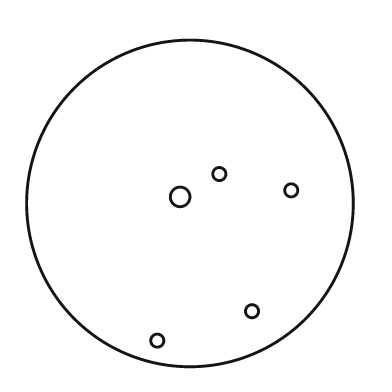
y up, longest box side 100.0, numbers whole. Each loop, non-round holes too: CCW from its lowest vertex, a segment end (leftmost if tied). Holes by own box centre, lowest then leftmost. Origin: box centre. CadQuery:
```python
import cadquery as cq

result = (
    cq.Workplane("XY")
    .moveTo(0.0, 0.0)
    .circle(50.0)
    .moveTo(-10.0, -42.0)
    .circle(2.0)
    .moveTo(19.0, -33.0)
    .circle(2.0)
    .moveTo(-3.0, 2.0)
    .circle(3.0)
    .moveTo(31.0, 4.0)
    .circle(2.0)
    .moveTo(9.0, 9.0)
    .circle(2.0)
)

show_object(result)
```